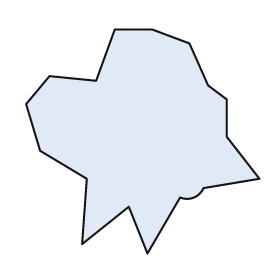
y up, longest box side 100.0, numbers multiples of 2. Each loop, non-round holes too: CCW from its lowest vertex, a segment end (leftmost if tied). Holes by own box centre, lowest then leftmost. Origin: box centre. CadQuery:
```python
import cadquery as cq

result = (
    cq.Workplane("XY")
    .moveTo(2.0, -48.0)
    .lineTo(16.0, -24.0)
    .threePointArc((22.0, -24.0), (26.0, -20.0))
    .lineTo(50.0, -16.0)
    .lineTo(36.0, 2.0)
    .lineTo(36.0, 18.0)
    .lineTo(28.0, 24.0)
    .lineTo(20.0, 42.0)
    .lineTo(4.0, 48.0)
    .lineTo(-12.0, 48.0)
    .lineTo(-20.0, 26.0)
    .lineTo(-40.0, 28.0)
    .lineTo(-50.0, 16.0)
    .lineTo(-44.0, -4.0)
    .lineTo(-24.0, -16.0)
    .lineTo(-26.0, -44.0)
    .lineTo(-6.0, -28.0)
    .close()
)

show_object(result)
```